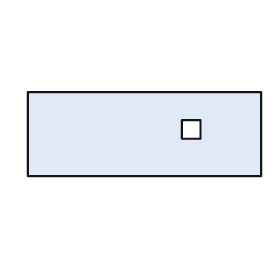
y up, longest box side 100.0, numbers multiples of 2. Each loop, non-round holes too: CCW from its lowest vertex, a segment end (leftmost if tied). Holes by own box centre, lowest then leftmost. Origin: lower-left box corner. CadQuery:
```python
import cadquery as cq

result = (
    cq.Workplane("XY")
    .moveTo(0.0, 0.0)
    .lineTo(100.0, 0.0)
    .lineTo(100.0, 36.0)
    .lineTo(0.0, 36.0)
    .close()
    .moveTo(66.0, 16.0)
    .lineTo(74.0, 16.0)
    .lineTo(74.0, 24.0)
    .lineTo(66.0, 24.0)
    .close()
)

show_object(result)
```